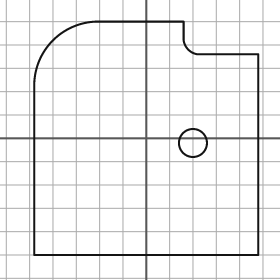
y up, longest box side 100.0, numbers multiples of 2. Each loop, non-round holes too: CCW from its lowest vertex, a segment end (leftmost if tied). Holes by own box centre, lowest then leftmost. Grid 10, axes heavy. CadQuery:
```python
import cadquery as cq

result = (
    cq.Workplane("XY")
    .moveTo(-48.0, -50.0)
    .lineTo(48.0, -50.0)
    .lineTo(48.0, 36.0)
    .lineTo(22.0, 36.0)
    .threePointArc((18.0, 38.0), (16.0, 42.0))
    .lineTo(16.0, 50.0)
    .lineTo(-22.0, 50.0)
    .threePointArc((-40.0, 42.0), (-48.0, 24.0))
    .close()
    .moveTo(20.0, -2.0)
    .circle(6.0)
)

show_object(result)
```